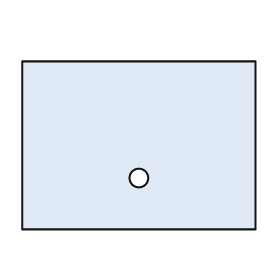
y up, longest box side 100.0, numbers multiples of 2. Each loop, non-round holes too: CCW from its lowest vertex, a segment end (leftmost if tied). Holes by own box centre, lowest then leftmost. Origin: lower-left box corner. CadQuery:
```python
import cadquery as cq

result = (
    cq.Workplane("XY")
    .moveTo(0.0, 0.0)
    .lineTo(100.0, 0.0)
    .lineTo(100.0, 72.0)
    .lineTo(0.0, 72.0)
    .close()
    .moveTo(50.0, 22.0)
    .circle(4.0)
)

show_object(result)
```